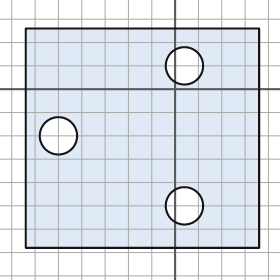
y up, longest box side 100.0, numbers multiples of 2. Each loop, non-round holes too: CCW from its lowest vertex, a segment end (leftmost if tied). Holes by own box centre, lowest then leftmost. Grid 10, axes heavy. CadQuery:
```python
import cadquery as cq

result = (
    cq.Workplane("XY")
    .moveTo(-64.0, -68.0)
    .lineTo(36.0, -68.0)
    .lineTo(36.0, 26.0)
    .lineTo(-64.0, 26.0)
    .close()
    .moveTo(4.0, -50.0)
    .circle(8.0)
    .moveTo(-50.0, -20.0)
    .circle(8.0)
    .moveTo(4.0, 10.0)
    .circle(8.0)
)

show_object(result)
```